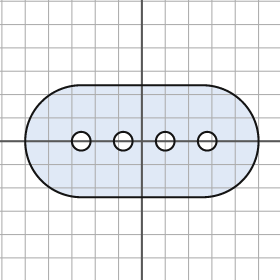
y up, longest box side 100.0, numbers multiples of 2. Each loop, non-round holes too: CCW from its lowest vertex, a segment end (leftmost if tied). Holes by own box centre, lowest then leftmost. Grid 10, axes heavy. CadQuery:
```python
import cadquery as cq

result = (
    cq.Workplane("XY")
    .moveTo(-26.0, -24.0)
    .lineTo(26.0, -24.0)
    .threePointArc((50.0, 0.0), (26.0, 24.0))
    .lineTo(-26.0, 24.0)
    .threePointArc((-50.0, 0.0), (-26.0, -24.0))
    .close()
    .moveTo(-26.0, 0.0)
    .circle(4.0)
    .moveTo(-8.0, 0.0)
    .circle(4.0)
    .moveTo(10.0, 0.0)
    .circle(4.0)
    .moveTo(28.0, 0.0)
    .circle(4.0)
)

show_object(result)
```